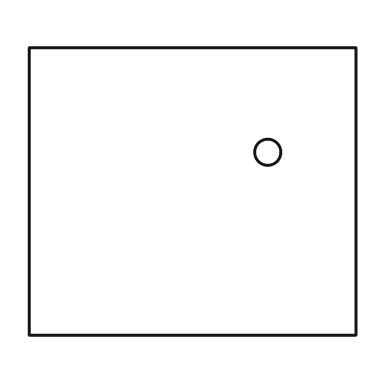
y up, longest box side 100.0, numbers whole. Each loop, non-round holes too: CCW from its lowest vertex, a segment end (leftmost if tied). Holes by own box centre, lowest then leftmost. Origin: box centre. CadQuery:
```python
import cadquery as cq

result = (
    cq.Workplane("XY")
    .moveTo(-50.0, -44.0)
    .lineTo(50.0, -44.0)
    .lineTo(50.0, 44.0)
    .lineTo(-50.0, 44.0)
    .close()
    .moveTo(23.0, 12.0)
    .circle(4.0)
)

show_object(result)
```